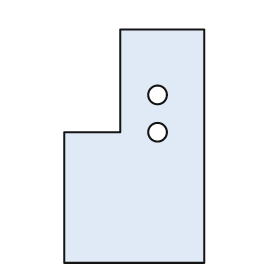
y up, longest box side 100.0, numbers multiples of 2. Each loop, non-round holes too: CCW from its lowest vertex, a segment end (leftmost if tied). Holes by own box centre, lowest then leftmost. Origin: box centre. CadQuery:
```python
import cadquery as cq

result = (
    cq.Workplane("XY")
    .moveTo(-30.0, -50.0)
    .lineTo(30.0, -50.0)
    .lineTo(30.0, 50.0)
    .lineTo(-6.0, 50.0)
    .lineTo(-6.0, 6.0)
    .lineTo(-30.0, 6.0)
    .close()
    .moveTo(10.0, 6.0)
    .circle(4.0)
    .moveTo(10.0, 22.0)
    .circle(4.0)
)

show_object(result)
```